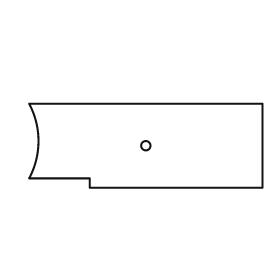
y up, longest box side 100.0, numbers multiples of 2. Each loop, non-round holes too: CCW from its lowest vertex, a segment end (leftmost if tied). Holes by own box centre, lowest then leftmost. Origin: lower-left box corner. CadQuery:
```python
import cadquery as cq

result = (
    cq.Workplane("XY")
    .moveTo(26.0, 0.0)
    .lineTo(100.0, 0.0)
    .lineTo(100.0, 36.0)
    .lineTo(0.0, 36.0)
    .threePointArc((4.0, 20.0), (0.0, 4.0))
    .lineTo(26.0, 4.0)
    .close()
    .moveTo(50.0, 18.0)
    .circle(2.0)
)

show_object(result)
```